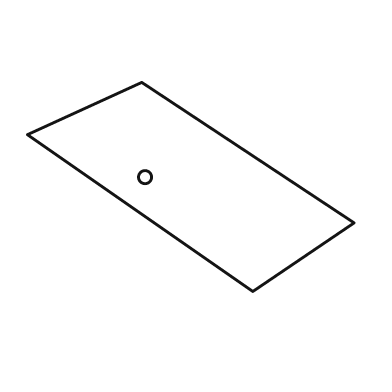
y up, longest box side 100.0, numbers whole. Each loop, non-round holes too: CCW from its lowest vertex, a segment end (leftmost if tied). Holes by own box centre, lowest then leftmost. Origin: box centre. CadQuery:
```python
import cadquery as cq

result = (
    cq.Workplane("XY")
    .moveTo(19.0, -32.0)
    .lineTo(50.0, -11.0)
    .lineTo(-15.0, 32.0)
    .lineTo(-50.0, 16.0)
    .close()
    .moveTo(-14.0, 3.0)
    .circle(2.0)
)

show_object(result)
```